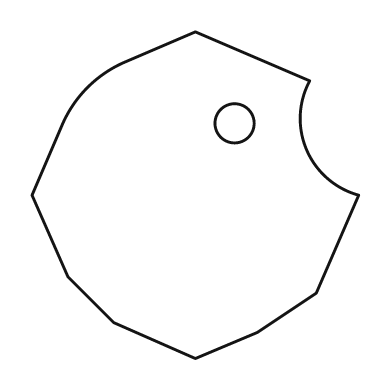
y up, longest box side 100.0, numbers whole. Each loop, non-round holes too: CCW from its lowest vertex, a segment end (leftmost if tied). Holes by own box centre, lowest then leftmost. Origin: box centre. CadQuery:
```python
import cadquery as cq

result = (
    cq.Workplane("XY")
    .moveTo(0.0, -50.0)
    .lineTo(19.0, -42.0)
    .lineTo(37.0, -30.0)
    .lineTo(50.0, 0.0)
    .threePointArc((34.0, 14.0), (35.0, 35.0))
    .lineTo(0.0, 50.0)
    .lineTo(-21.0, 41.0)
    .threePointArc((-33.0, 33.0), (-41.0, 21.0))
    .lineTo(-50.0, 0.0)
    .lineTo(-39.0, -25.0)
    .lineTo(-25.0, -39.0)
    .close()
    .moveTo(12.0, 22.0)
    .circle(6.0)
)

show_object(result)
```